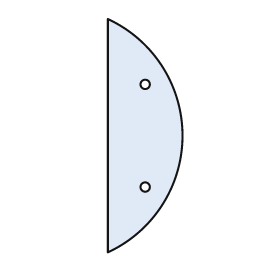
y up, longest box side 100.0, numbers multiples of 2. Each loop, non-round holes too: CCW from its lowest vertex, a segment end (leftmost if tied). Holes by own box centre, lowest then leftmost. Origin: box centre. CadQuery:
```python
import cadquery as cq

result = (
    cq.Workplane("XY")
    .moveTo(-16.0, -50.0)
    .threePointArc((16.0, 0.0), (-16.0, 50.0))
    .close()
    .moveTo(0.0, -22.0)
    .circle(2.0)
    .moveTo(0.0, 22.0)
    .circle(2.0)
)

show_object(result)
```